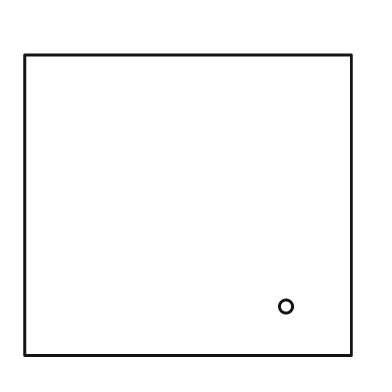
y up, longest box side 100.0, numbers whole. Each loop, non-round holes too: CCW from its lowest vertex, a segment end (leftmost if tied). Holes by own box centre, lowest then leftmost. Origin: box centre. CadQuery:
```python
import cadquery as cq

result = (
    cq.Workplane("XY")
    .moveTo(-50.0, -46.0)
    .lineTo(50.0, -46.0)
    .lineTo(50.0, 46.0)
    .lineTo(-50.0, 46.0)
    .close()
    .moveTo(30.0, -31.0)
    .circle(2.0)
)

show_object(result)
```